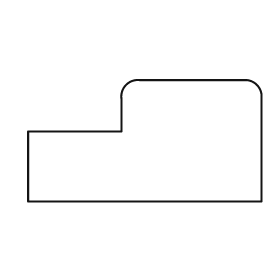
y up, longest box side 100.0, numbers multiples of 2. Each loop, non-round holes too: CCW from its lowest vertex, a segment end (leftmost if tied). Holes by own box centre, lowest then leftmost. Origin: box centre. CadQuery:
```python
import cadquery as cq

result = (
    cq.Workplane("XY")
    .moveTo(-50.0, -26.0)
    .lineTo(50.0, -26.0)
    .lineTo(50.0, 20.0)
    .threePointArc((48.0, 24.0), (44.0, 26.0))
    .lineTo(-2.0, 26.0)
    .threePointArc((-8.0, 24.0), (-10.0, 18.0))
    .lineTo(-10.0, 4.0)
    .lineTo(-50.0, 4.0)
    .close()
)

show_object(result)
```